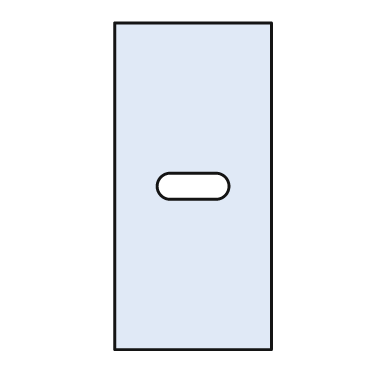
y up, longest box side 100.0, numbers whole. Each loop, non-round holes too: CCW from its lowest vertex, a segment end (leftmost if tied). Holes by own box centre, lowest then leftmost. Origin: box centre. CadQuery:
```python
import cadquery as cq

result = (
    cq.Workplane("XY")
    .moveTo(-24.0, -50.0)
    .lineTo(24.0, -50.0)
    .lineTo(24.0, 50.0)
    .lineTo(-24.0, 50.0)
    .close()
    .moveTo(-7.0, -4.0)
    .lineTo(7.0, -4.0)
    .threePointArc((11.0, 0.0), (7.0, 4.0))
    .lineTo(-7.0, 4.0)
    .threePointArc((-11.0, 0.0), (-7.0, -4.0))
    .close()
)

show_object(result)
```